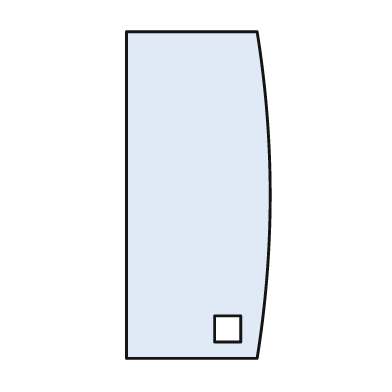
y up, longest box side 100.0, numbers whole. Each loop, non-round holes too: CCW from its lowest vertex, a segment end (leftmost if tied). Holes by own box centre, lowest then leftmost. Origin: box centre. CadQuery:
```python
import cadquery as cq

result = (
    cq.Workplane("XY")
    .moveTo(-22.0, -50.0)
    .lineTo(18.0, -50.0)
    .threePointArc((22.0, 0.0), (18.0, 50.0))
    .lineTo(-22.0, 50.0)
    .close()
    .moveTo(5.0, -45.0)
    .lineTo(13.0, -45.0)
    .lineTo(13.0, -37.0)
    .lineTo(5.0, -37.0)
    .close()
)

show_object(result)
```